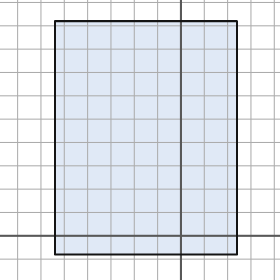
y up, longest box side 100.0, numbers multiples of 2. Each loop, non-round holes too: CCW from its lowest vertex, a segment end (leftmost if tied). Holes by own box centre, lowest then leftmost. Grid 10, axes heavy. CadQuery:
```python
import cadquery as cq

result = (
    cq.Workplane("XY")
    .moveTo(-54.0, -8.0)
    .lineTo(24.0, -8.0)
    .lineTo(24.0, 92.0)
    .lineTo(-54.0, 92.0)
    .close()
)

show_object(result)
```